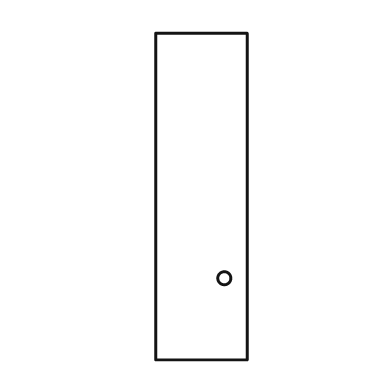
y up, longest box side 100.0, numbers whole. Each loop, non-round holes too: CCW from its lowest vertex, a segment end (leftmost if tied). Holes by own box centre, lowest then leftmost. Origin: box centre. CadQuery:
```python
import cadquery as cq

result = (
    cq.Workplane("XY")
    .moveTo(-14.0, -50.0)
    .lineTo(14.0, -50.0)
    .lineTo(14.0, 50.0)
    .lineTo(-14.0, 50.0)
    .close()
    .moveTo(7.0, -25.0)
    .circle(2.0)
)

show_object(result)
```